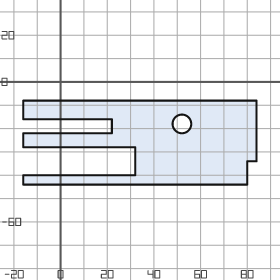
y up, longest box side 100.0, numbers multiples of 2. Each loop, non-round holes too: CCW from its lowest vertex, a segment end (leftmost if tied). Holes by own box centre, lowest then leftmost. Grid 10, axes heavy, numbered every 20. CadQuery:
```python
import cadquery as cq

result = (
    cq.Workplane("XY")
    .moveTo(-16.0, -44.0)
    .lineTo(80.0, -44.0)
    .lineTo(80.0, -34.0)
    .lineTo(84.0, -34.0)
    .lineTo(84.0, -8.0)
    .lineTo(-16.0, -8.0)
    .lineTo(-16.0, -16.0)
    .lineTo(22.0, -16.0)
    .lineTo(22.0, -22.0)
    .lineTo(-16.0, -22.0)
    .lineTo(-16.0, -28.0)
    .lineTo(32.0, -28.0)
    .lineTo(32.0, -40.0)
    .lineTo(-16.0, -40.0)
    .close()
    .moveTo(52.0, -18.0)
    .circle(4.0)
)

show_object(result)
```